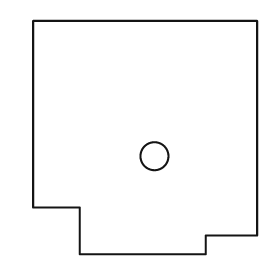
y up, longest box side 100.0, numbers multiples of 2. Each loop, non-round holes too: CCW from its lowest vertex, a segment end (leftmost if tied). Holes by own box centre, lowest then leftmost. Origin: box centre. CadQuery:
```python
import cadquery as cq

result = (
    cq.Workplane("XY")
    .moveTo(-28.0, -50.0)
    .lineTo(26.0, -50.0)
    .lineTo(26.0, -42.0)
    .lineTo(48.0, -42.0)
    .lineTo(48.0, 50.0)
    .lineTo(-48.0, 50.0)
    .lineTo(-48.0, -30.0)
    .lineTo(-28.0, -30.0)
    .close()
    .moveTo(4.0, -8.0)
    .circle(6.0)
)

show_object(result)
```